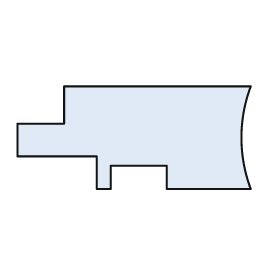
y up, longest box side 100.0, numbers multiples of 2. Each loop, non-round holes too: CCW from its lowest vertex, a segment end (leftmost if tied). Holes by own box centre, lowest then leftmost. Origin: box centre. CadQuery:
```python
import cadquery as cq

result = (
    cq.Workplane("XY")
    .moveTo(-16.0, -22.0)
    .lineTo(-10.0, -22.0)
    .lineTo(-10.0, -12.0)
    .lineTo(14.0, -12.0)
    .lineTo(14.0, -22.0)
    .lineTo(50.0, -22.0)
    .threePointArc((46.0, 0.0), (50.0, 22.0))
    .lineTo(-30.0, 22.0)
    .lineTo(-30.0, 6.0)
    .lineTo(-50.0, 6.0)
    .lineTo(-50.0, -8.0)
    .lineTo(-16.0, -8.0)
    .close()
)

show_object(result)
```